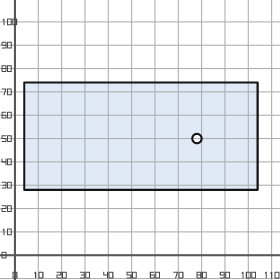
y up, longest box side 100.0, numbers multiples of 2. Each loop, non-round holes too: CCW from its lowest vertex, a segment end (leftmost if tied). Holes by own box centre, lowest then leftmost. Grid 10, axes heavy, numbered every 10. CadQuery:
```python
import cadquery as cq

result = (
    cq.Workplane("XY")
    .moveTo(4.0, 28.0)
    .lineTo(104.0, 28.0)
    .lineTo(104.0, 74.0)
    .lineTo(4.0, 74.0)
    .close()
    .moveTo(78.0, 50.0)
    .circle(2.0)
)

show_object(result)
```